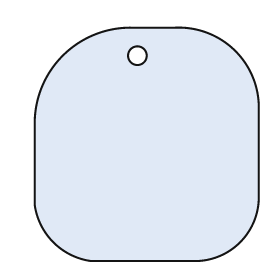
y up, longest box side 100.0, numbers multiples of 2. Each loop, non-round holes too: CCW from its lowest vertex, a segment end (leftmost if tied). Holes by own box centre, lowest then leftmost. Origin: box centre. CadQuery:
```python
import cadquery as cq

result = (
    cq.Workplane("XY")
    .moveTo(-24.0, -50.0)
    .lineTo(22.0, -50.0)
    .threePointArc((40.0, -42.0), (48.0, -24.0))
    .lineTo(48.0, 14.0)
    .threePointArc((38.0, 40.0), (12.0, 50.0))
    .lineTo(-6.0, 50.0)
    .threePointArc((-36.0, 38.0), (-48.0, 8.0))
    .lineTo(-48.0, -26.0)
    .threePointArc((-40.0, -42.0), (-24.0, -50.0))
    .close()
    .moveTo(-4.0, 38.0)
    .circle(4.0)
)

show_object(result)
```